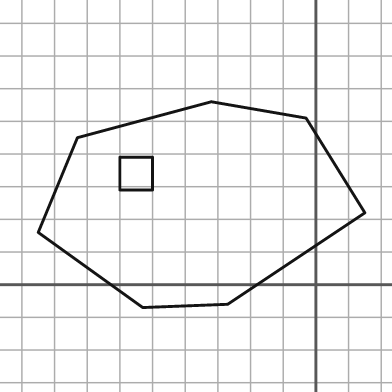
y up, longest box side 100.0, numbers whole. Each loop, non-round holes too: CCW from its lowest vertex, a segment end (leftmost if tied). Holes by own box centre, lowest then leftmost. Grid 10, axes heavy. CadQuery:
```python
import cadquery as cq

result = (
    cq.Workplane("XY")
    .moveTo(-53.0, -7.0)
    .lineTo(-27.0, -6.0)
    .lineTo(15.0, 22.0)
    .lineTo(-3.0, 51.0)
    .lineTo(-32.0, 56.0)
    .lineTo(-73.0, 45.0)
    .lineTo(-85.0, 16.0)
    .close()
    .moveTo(-60.0, 29.0)
    .lineTo(-50.0, 29.0)
    .lineTo(-50.0, 39.0)
    .lineTo(-60.0, 39.0)
    .close()
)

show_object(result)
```